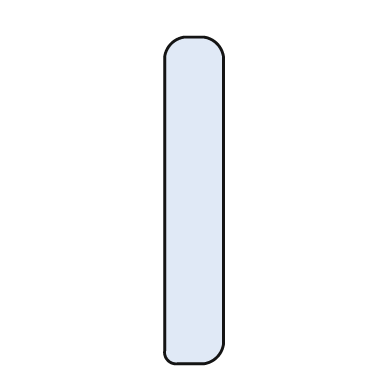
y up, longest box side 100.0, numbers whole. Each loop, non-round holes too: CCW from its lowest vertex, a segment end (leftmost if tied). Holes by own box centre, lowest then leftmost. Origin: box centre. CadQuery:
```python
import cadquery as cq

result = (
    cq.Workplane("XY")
    .moveTo(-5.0, -50.0)
    .lineTo(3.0, -50.0)
    .threePointArc((7.0, -48.0), (9.0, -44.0))
    .lineTo(9.0, 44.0)
    .threePointArc((7.0, 48.0), (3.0, 50.0))
    .lineTo(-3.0, 50.0)
    .threePointArc((-7.0, 48.0), (-9.0, 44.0))
    .lineTo(-9.0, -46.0)
    .threePointArc((-8.0, -49.0), (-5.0, -50.0))
    .close()
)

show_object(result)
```